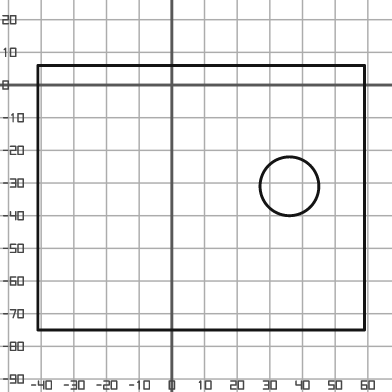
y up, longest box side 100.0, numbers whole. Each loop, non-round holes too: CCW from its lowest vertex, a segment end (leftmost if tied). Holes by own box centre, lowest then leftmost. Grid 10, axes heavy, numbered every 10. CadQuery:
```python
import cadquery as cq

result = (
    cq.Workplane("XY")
    .moveTo(-41.0, -75.0)
    .lineTo(59.0, -75.0)
    .lineTo(59.0, 6.0)
    .lineTo(-41.0, 6.0)
    .close()
    .moveTo(36.0, -31.0)
    .circle(9.0)
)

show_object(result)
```